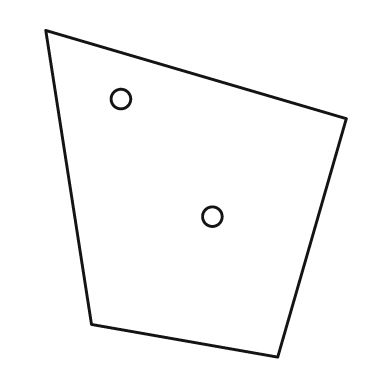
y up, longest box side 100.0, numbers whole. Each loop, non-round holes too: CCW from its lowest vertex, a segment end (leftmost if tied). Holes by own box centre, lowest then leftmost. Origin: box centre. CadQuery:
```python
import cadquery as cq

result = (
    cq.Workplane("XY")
    .moveTo(25.0, -50.0)
    .lineTo(46.0, 23.0)
    .lineTo(-46.0, 50.0)
    .lineTo(-32.0, -40.0)
    .close()
    .moveTo(5.0, -7.0)
    .circle(3.0)
    .moveTo(-23.0, 29.0)
    .circle(3.0)
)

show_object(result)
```